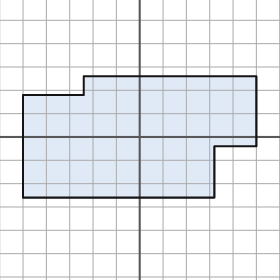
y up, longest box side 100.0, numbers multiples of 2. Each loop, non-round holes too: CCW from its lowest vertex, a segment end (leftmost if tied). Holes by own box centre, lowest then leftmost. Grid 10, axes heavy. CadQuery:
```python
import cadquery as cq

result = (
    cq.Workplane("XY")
    .moveTo(-50.0, -26.0)
    .lineTo(32.0, -26.0)
    .lineTo(32.0, -4.0)
    .lineTo(50.0, -4.0)
    .lineTo(50.0, 26.0)
    .lineTo(-24.0, 26.0)
    .lineTo(-24.0, 18.0)
    .lineTo(-50.0, 18.0)
    .close()
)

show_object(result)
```